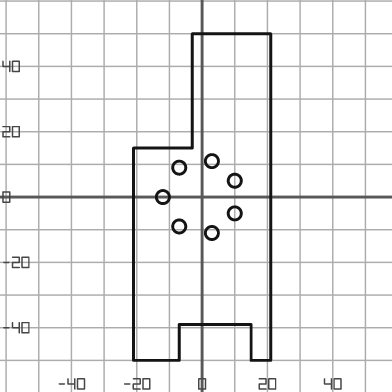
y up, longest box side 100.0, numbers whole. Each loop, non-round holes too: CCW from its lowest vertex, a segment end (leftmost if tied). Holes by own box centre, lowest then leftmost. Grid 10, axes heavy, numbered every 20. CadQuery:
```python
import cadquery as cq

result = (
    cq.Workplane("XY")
    .moveTo(-21.0, -50.0)
    .lineTo(-7.0, -50.0)
    .lineTo(-7.0, -39.0)
    .lineTo(15.0, -39.0)
    .lineTo(15.0, -50.0)
    .lineTo(21.0, -50.0)
    .lineTo(21.0, 50.0)
    .lineTo(-3.0, 50.0)
    .lineTo(-3.0, 15.0)
    .lineTo(-21.0, 15.0)
    .close()
    .moveTo(3.0, -11.0)
    .circle(2.0)
    .moveTo(-7.0, -9.0)
    .circle(2.0)
    .moveTo(10.0, -5.0)
    .circle(2.0)
    .moveTo(-12.0, 0.0)
    .circle(2.0)
    .moveTo(10.0, 5.0)
    .circle(2.0)
    .moveTo(-7.0, 9.0)
    .circle(2.0)
    .moveTo(3.0, 11.0)
    .circle(2.0)
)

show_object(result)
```